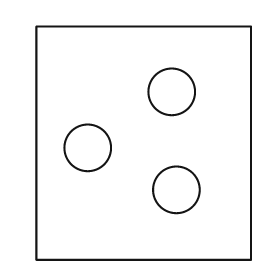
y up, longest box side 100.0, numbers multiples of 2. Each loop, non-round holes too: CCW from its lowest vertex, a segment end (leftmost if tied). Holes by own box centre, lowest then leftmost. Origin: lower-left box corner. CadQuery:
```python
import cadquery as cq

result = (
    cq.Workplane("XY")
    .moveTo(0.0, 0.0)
    .lineTo(92.0, 0.0)
    .lineTo(92.0, 100.0)
    .lineTo(0.0, 100.0)
    .close()
    .moveTo(60.0, 30.0)
    .circle(10.0)
    .moveTo(22.0, 48.0)
    .circle(10.0)
    .moveTo(58.0, 72.0)
    .circle(10.0)
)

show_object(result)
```